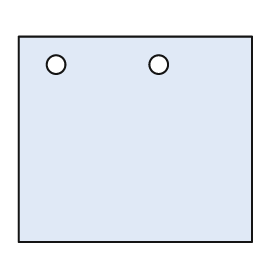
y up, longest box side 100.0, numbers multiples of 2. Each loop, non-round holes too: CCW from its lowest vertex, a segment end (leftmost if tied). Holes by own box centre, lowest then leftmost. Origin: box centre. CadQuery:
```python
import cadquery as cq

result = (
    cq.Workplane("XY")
    .moveTo(-50.0, -44.0)
    .lineTo(50.0, -44.0)
    .lineTo(50.0, 44.0)
    .lineTo(-50.0, 44.0)
    .close()
    .moveTo(-34.0, 32.0)
    .circle(4.0)
    .moveTo(10.0, 32.0)
    .circle(4.0)
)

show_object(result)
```